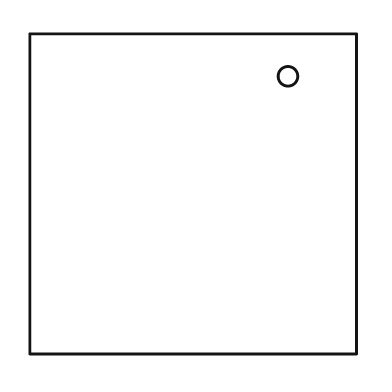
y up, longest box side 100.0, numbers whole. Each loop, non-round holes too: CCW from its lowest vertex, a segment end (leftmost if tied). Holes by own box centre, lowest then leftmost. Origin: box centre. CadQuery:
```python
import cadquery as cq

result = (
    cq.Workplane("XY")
    .moveTo(-50.0, -49.0)
    .lineTo(50.0, -49.0)
    .lineTo(50.0, 49.0)
    .lineTo(-50.0, 49.0)
    .close()
    .moveTo(29.0, 36.0)
    .circle(3.0)
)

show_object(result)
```